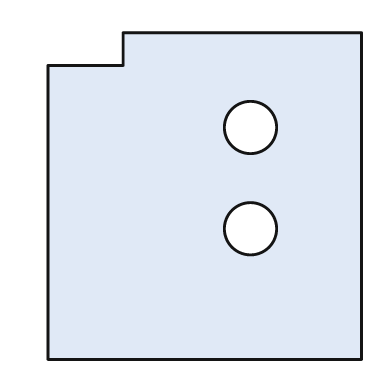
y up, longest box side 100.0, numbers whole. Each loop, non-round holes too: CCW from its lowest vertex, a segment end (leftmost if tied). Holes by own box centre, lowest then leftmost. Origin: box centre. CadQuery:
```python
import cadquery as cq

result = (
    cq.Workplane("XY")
    .moveTo(-48.0, -50.0)
    .lineTo(48.0, -50.0)
    .lineTo(48.0, 50.0)
    .lineTo(-25.0, 50.0)
    .lineTo(-25.0, 40.0)
    .lineTo(-48.0, 40.0)
    .close()
    .moveTo(14.0, -10.0)
    .circle(8.0)
    .moveTo(14.0, 21.0)
    .circle(8.0)
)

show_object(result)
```